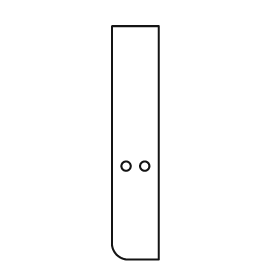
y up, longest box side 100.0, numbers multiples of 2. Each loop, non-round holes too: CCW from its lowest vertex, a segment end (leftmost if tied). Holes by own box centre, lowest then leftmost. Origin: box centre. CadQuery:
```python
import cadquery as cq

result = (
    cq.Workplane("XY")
    .moveTo(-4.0, -50.0)
    .lineTo(10.0, -50.0)
    .lineTo(10.0, 50.0)
    .lineTo(-10.0, 50.0)
    .lineTo(-10.0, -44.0)
    .threePointArc((-8.0, -48.0), (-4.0, -50.0))
    .close()
    .moveTo(-4.0, -10.0)
    .circle(2.0)
    .moveTo(4.0, -10.0)
    .circle(2.0)
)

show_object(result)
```